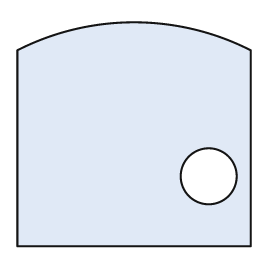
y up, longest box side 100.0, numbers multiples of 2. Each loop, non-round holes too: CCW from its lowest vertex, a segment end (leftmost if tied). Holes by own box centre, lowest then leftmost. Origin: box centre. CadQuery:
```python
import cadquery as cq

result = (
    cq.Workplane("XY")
    .moveTo(-50.0, -48.0)
    .lineTo(50.0, -48.0)
    .lineTo(50.0, 36.0)
    .threePointArc((0.0, 48.0), (-50.0, 36.0))
    .close()
    .moveTo(32.0, -18.0)
    .circle(12.0)
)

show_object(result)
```